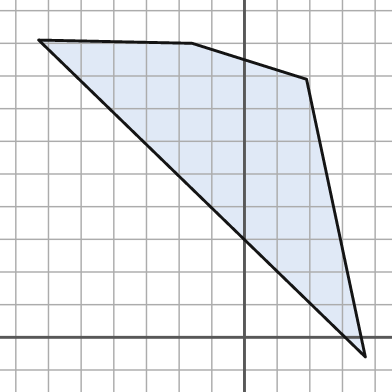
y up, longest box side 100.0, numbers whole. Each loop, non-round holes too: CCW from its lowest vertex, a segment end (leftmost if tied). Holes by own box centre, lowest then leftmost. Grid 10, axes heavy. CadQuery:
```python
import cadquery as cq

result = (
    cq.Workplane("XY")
    .moveTo(37.0, -6.0)
    .lineTo(19.0, 79.0)
    .lineTo(-16.0, 90.0)
    .lineTo(-63.0, 91.0)
    .close()
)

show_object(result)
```